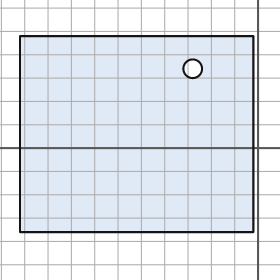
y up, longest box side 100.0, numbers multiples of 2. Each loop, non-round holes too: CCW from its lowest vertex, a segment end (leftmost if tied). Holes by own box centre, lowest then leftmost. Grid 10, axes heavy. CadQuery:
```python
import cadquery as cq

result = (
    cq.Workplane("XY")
    .moveTo(-102.0, -36.0)
    .lineTo(-2.0, -36.0)
    .lineTo(-2.0, 48.0)
    .lineTo(-102.0, 48.0)
    .close()
    .moveTo(-28.0, 34.0)
    .circle(4.0)
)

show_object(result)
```